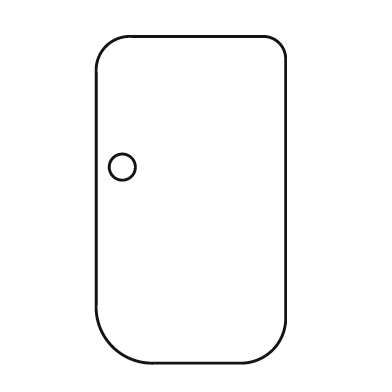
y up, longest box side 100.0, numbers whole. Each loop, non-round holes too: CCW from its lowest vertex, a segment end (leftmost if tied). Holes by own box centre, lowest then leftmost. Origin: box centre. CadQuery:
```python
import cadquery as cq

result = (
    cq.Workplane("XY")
    .moveTo(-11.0, -50.0)
    .lineTo(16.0, -50.0)
    .threePointArc((25.0, -46.0), (29.0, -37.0))
    .lineTo(29.0, 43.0)
    .threePointArc((27.0, 48.0), (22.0, 50.0))
    .lineTo(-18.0, 50.0)
    .threePointArc((-26.0, 47.0), (-29.0, 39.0))
    .lineTo(-29.0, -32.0)
    .threePointArc((-24.0, -45.0), (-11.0, -50.0))
    .close()
    .moveTo(-21.0, 10.0)
    .circle(4.0)
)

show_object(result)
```